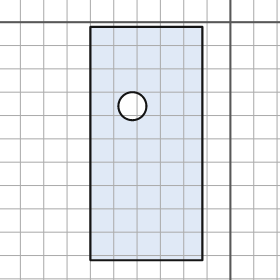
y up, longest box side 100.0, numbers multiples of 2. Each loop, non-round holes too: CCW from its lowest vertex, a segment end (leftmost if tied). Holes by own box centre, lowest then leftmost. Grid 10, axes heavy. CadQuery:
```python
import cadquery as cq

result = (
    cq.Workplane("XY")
    .moveTo(-60.0, -102.0)
    .lineTo(-12.0, -102.0)
    .lineTo(-12.0, -2.0)
    .lineTo(-60.0, -2.0)
    .close()
    .moveTo(-42.0, -36.0)
    .circle(6.0)
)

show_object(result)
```